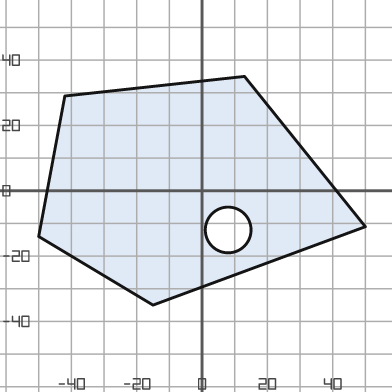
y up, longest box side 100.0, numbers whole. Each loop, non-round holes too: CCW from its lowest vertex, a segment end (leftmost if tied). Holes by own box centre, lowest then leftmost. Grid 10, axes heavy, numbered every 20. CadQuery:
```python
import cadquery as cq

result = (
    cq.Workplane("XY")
    .moveTo(-15.0, -35.0)
    .lineTo(50.0, -11.0)
    .lineTo(13.0, 35.0)
    .lineTo(-42.0, 29.0)
    .lineTo(-50.0, -14.0)
    .close()
    .moveTo(8.0, -12.0)
    .circle(7.0)
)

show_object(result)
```